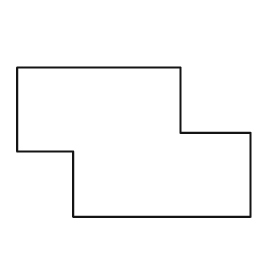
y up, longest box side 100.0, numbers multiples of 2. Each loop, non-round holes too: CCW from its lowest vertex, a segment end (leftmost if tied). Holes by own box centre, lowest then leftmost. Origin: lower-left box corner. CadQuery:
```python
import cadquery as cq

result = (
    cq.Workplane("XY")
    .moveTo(24.0, 0.0)
    .lineTo(100.0, 0.0)
    .lineTo(100.0, 36.0)
    .lineTo(70.0, 36.0)
    .lineTo(70.0, 64.0)
    .lineTo(0.0, 64.0)
    .lineTo(0.0, 28.0)
    .lineTo(24.0, 28.0)
    .close()
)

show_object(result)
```